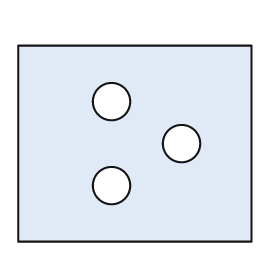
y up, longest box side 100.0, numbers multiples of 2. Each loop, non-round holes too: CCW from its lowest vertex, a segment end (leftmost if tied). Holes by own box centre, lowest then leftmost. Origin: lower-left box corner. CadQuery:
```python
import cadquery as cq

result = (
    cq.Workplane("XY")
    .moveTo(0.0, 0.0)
    .lineTo(100.0, 0.0)
    .lineTo(100.0, 84.0)
    .lineTo(0.0, 84.0)
    .close()
    .moveTo(40.0, 24.0)
    .circle(8.0)
    .moveTo(70.0, 42.0)
    .circle(8.0)
    .moveTo(40.0, 60.0)
    .circle(8.0)
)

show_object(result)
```